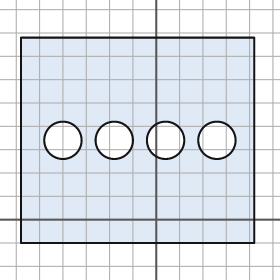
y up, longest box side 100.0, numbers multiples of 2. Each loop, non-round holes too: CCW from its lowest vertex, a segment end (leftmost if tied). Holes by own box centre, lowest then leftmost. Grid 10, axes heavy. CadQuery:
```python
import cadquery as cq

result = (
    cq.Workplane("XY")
    .moveTo(-58.0, -10.0)
    .lineTo(42.0, -10.0)
    .lineTo(42.0, 78.0)
    .lineTo(-58.0, 78.0)
    .close()
    .moveTo(-40.0, 34.0)
    .circle(8.0)
    .moveTo(-18.0, 34.0)
    .circle(8.0)
    .moveTo(4.0, 34.0)
    .circle(8.0)
    .moveTo(26.0, 34.0)
    .circle(8.0)
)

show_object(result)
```